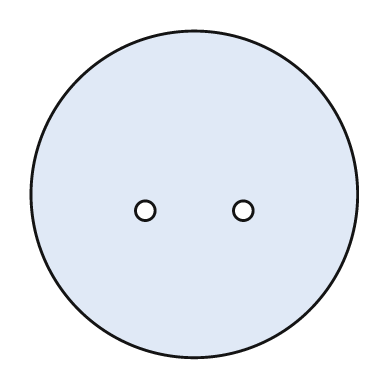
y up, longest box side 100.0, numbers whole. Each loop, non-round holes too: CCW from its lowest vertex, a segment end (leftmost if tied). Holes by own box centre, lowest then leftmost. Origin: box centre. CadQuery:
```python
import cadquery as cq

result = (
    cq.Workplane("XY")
    .moveTo(0.0, 0.0)
    .circle(50.0)
    .moveTo(-15.0, -5.0)
    .circle(3.0)
    .moveTo(15.0, -5.0)
    .circle(3.0)
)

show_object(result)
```